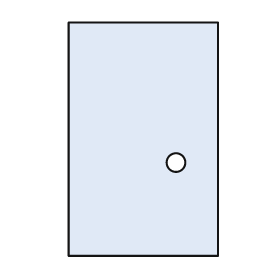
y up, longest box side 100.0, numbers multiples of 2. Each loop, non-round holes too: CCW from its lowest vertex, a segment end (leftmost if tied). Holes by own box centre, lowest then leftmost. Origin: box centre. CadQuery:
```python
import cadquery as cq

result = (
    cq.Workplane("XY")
    .moveTo(-32.0, -50.0)
    .lineTo(32.0, -50.0)
    .lineTo(32.0, 50.0)
    .lineTo(-32.0, 50.0)
    .close()
    .moveTo(14.0, -10.0)
    .circle(4.0)
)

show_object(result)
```